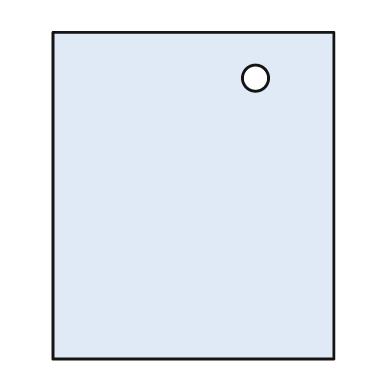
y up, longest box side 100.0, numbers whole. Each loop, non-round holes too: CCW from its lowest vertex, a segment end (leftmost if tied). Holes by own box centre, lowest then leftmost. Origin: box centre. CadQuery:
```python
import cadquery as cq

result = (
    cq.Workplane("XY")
    .moveTo(-43.0, -50.0)
    .lineTo(43.0, -50.0)
    .lineTo(43.0, 50.0)
    .lineTo(-43.0, 50.0)
    .close()
    .moveTo(19.0, 36.0)
    .circle(4.0)
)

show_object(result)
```